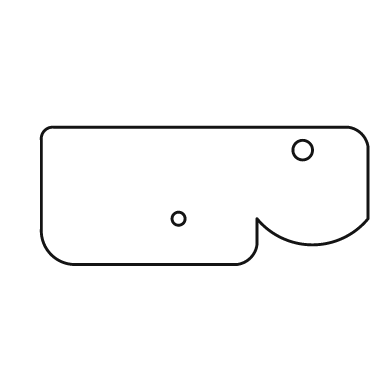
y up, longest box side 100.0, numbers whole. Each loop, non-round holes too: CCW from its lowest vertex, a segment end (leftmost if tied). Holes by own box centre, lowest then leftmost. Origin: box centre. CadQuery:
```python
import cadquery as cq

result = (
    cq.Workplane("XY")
    .moveTo(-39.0, -21.0)
    .lineTo(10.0, -21.0)
    .threePointArc((14.0, -19.0), (16.0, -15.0))
    .lineTo(16.0, -7.0)
    .threePointArc((33.0, -15.0), (50.0, -7.0))
    .lineTo(50.0, 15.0)
    .threePointArc((48.0, 19.0), (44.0, 21.0))
    .lineTo(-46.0, 21.0)
    .threePointArc((-49.0, 20.0), (-50.0, 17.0))
    .lineTo(-50.0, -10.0)
    .threePointArc((-47.0, -18.0), (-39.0, -21.0))
    .close()
    .moveTo(-8.0, -7.0)
    .circle(2.0)
    .moveTo(30.0, 14.0)
    .circle(3.0)
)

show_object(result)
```